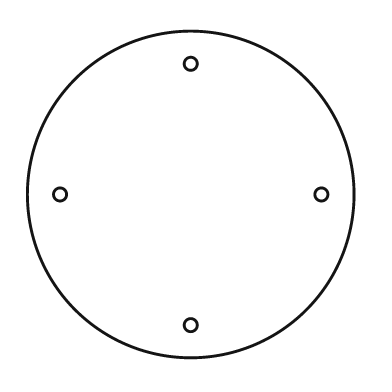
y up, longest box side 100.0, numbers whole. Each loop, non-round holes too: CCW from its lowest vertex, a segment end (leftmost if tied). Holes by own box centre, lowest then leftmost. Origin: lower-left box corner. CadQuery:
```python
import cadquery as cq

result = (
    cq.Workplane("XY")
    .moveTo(50.0, 50.0)
    .circle(50.0)
    .moveTo(50.0, 10.0)
    .circle(2.0)
    .moveTo(10.0, 50.0)
    .circle(2.0)
    .moveTo(90.0, 50.0)
    .circle(2.0)
    .moveTo(50.0, 90.0)
    .circle(2.0)
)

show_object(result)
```